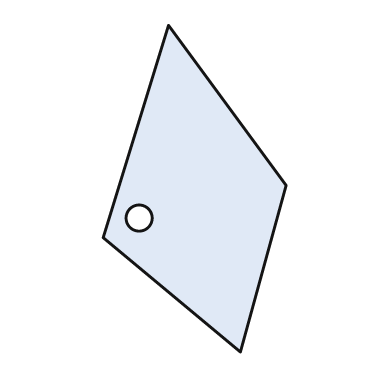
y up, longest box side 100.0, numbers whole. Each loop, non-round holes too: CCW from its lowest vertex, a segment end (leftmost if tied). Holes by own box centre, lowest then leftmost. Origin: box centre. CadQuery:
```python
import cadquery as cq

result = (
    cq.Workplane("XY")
    .moveTo(14.0, -50.0)
    .lineTo(28.0, 1.0)
    .lineTo(-8.0, 50.0)
    .lineTo(-28.0, -15.0)
    .close()
    .moveTo(-17.0, -9.0)
    .circle(4.0)
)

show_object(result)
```